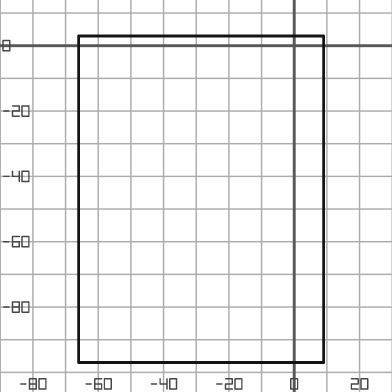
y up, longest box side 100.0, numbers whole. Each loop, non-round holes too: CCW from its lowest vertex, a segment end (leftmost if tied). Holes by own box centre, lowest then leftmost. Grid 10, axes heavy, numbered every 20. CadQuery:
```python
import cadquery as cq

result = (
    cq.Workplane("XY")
    .moveTo(-66.0, -97.0)
    .lineTo(9.0, -97.0)
    .lineTo(9.0, 3.0)
    .lineTo(-66.0, 3.0)
    .close()
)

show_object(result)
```